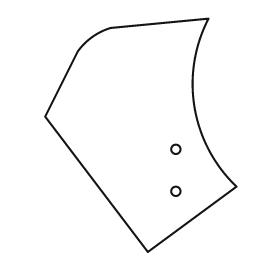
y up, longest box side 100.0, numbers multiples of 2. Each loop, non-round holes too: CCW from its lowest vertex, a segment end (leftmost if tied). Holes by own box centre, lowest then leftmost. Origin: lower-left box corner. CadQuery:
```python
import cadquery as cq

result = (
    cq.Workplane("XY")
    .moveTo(44.0, 0.0)
    .lineTo(82.0, 28.0)
    .threePointArc((64.0, 62.0), (70.0, 100.0))
    .lineTo(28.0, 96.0)
    .threePointArc((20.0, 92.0), (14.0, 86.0))
    .lineTo(0.0, 58.0)
    .close()
    .moveTo(56.0, 26.0)
    .circle(2.0)
    .moveTo(56.0, 44.0)
    .circle(2.0)
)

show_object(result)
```